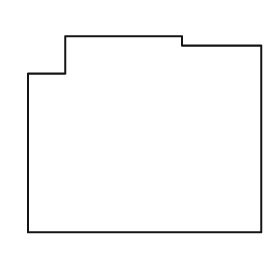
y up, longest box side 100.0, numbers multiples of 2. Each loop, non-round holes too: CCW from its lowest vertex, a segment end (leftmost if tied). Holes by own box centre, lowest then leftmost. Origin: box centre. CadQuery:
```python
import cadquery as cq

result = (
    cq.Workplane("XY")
    .moveTo(-50.0, -42.0)
    .lineTo(50.0, -42.0)
    .lineTo(50.0, 38.0)
    .lineTo(16.0, 38.0)
    .lineTo(16.0, 42.0)
    .lineTo(-34.0, 42.0)
    .lineTo(-34.0, 26.0)
    .lineTo(-50.0, 26.0)
    .close()
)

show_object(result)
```